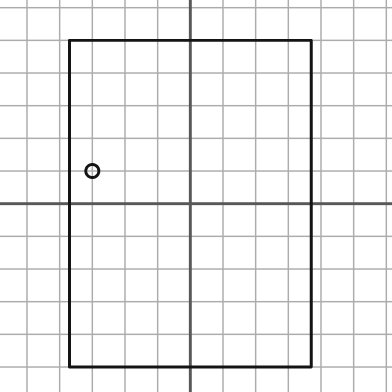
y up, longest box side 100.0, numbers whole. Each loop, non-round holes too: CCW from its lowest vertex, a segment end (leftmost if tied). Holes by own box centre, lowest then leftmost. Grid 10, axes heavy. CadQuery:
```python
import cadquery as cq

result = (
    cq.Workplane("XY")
    .moveTo(-37.0, -50.0)
    .lineTo(37.0, -50.0)
    .lineTo(37.0, 50.0)
    .lineTo(-37.0, 50.0)
    .close()
    .moveTo(-30.0, 10.0)
    .circle(2.0)
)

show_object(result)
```